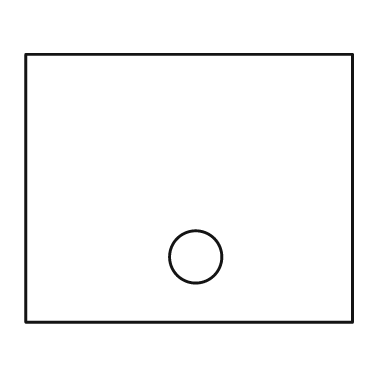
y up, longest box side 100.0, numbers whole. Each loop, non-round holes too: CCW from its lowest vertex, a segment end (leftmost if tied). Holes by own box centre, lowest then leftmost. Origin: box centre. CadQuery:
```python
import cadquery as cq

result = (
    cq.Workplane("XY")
    .moveTo(-50.0, -41.0)
    .lineTo(50.0, -41.0)
    .lineTo(50.0, 41.0)
    .lineTo(-50.0, 41.0)
    .close()
    .moveTo(2.0, -21.0)
    .circle(8.0)
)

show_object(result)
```